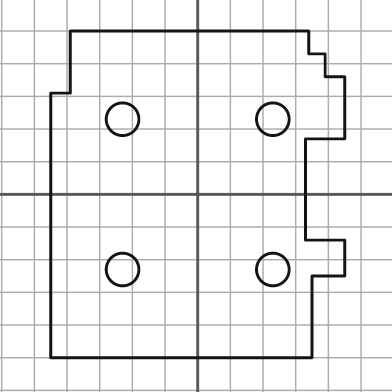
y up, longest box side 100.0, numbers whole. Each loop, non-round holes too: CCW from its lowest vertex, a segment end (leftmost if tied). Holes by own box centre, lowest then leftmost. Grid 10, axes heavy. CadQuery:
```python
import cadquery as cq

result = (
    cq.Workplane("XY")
    .moveTo(-45.0, -50.0)
    .lineTo(35.0, -50.0)
    .lineTo(35.0, -25.0)
    .lineTo(45.0, -25.0)
    .lineTo(45.0, -14.0)
    .lineTo(33.0, -14.0)
    .lineTo(33.0, 17.0)
    .lineTo(45.0, 17.0)
    .lineTo(45.0, 36.0)
    .lineTo(39.0, 36.0)
    .lineTo(39.0, 43.0)
    .lineTo(34.0, 43.0)
    .lineTo(34.0, 50.0)
    .lineTo(-39.0, 50.0)
    .lineTo(-39.0, 31.0)
    .lineTo(-45.0, 31.0)
    .close()
    .moveTo(-23.0, -23.0)
    .circle(5.0)
    .moveTo(23.0, -23.0)
    .circle(5.0)
    .moveTo(-23.0, 23.0)
    .circle(5.0)
    .moveTo(23.0, 23.0)
    .circle(5.0)
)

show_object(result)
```